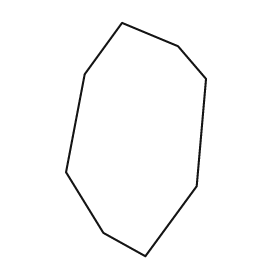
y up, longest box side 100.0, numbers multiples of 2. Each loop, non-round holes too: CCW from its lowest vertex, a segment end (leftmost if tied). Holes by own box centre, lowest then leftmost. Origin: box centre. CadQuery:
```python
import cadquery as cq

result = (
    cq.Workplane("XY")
    .moveTo(4.0, -50.0)
    .lineTo(26.0, -20.0)
    .lineTo(30.0, 26.0)
    .lineTo(18.0, 40.0)
    .lineTo(-6.0, 50.0)
    .lineTo(-22.0, 28.0)
    .lineTo(-30.0, -14.0)
    .lineTo(-14.0, -40.0)
    .close()
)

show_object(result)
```